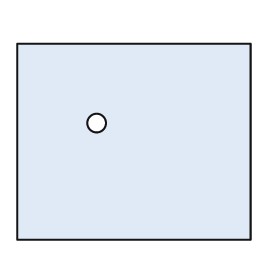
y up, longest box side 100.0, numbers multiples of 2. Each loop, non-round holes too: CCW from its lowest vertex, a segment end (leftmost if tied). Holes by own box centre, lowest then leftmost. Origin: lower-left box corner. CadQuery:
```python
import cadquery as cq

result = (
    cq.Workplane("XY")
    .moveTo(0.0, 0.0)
    .lineTo(100.0, 0.0)
    .lineTo(100.0, 84.0)
    .lineTo(0.0, 84.0)
    .close()
    .moveTo(34.0, 50.0)
    .circle(4.0)
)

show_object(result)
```